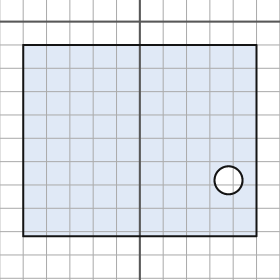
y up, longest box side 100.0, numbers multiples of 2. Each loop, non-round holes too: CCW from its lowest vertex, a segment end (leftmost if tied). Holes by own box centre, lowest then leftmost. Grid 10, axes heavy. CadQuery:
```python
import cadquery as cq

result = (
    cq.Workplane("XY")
    .moveTo(-50.0, -92.0)
    .lineTo(50.0, -92.0)
    .lineTo(50.0, -10.0)
    .lineTo(-50.0, -10.0)
    .close()
    .moveTo(38.0, -68.0)
    .circle(6.0)
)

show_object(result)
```